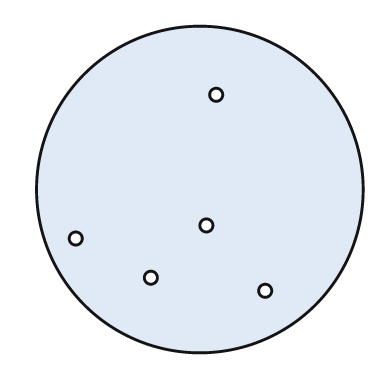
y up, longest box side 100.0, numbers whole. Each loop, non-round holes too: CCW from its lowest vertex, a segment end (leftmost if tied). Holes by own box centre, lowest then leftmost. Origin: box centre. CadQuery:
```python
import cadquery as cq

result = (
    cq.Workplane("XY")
    .moveTo(0.0, 0.0)
    .circle(50.0)
    .moveTo(20.0, -31.0)
    .circle(2.0)
    .moveTo(-15.0, -27.0)
    .circle(2.0)
    .moveTo(-38.0, -15.0)
    .circle(2.0)
    .moveTo(2.0, -11.0)
    .circle(2.0)
    .moveTo(5.0, 29.0)
    .circle(2.0)
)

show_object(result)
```